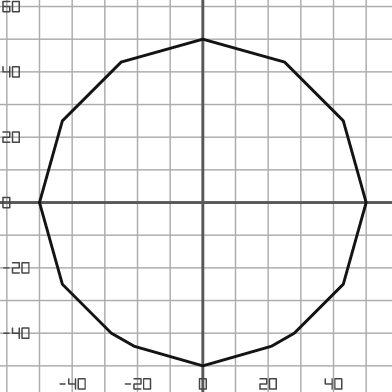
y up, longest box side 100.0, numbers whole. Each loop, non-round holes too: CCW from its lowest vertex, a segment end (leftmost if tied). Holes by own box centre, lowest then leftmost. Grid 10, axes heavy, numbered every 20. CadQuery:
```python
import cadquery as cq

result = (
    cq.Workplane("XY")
    .moveTo(0.0, -50.0)
    .lineTo(21.0, -44.0)
    .lineTo(28.0, -40.0)
    .lineTo(43.0, -25.0)
    .lineTo(50.0, 0.0)
    .lineTo(43.0, 25.0)
    .lineTo(25.0, 43.0)
    .lineTo(0.0, 50.0)
    .lineTo(-25.0, 43.0)
    .lineTo(-43.0, 25.0)
    .lineTo(-50.0, 0.0)
    .lineTo(-43.0, -25.0)
    .lineTo(-28.0, -40.0)
    .lineTo(-21.0, -44.0)
    .close()
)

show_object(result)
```